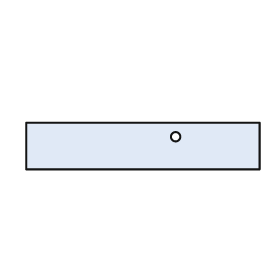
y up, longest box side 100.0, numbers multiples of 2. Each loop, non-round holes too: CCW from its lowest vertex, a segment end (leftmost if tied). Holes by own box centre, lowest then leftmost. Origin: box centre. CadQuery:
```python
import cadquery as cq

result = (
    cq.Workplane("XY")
    .moveTo(-50.0, -10.0)
    .lineTo(50.0, -10.0)
    .lineTo(50.0, 10.0)
    .lineTo(-50.0, 10.0)
    .close()
    .moveTo(14.0, 4.0)
    .circle(2.0)
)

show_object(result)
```